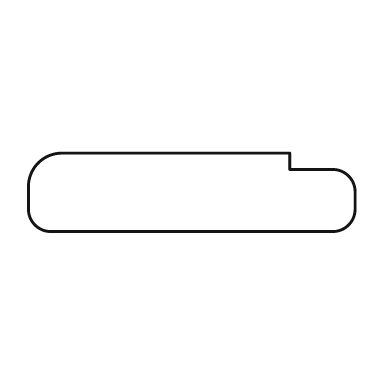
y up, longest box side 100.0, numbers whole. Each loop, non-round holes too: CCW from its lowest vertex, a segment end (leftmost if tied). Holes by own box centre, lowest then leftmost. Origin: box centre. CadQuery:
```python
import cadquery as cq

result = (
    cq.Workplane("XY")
    .moveTo(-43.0, -12.0)
    .lineTo(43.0, -12.0)
    .threePointArc((48.0, -10.0), (50.0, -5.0))
    .lineTo(50.0, 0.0)
    .threePointArc((48.0, 5.0), (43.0, 7.0))
    .lineTo(30.0, 7.0)
    .lineTo(30.0, 12.0)
    .lineTo(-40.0, 12.0)
    .threePointArc((-47.0, 9.0), (-50.0, 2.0))
    .lineTo(-50.0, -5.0)
    .threePointArc((-48.0, -10.0), (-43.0, -12.0))
    .close()
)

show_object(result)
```